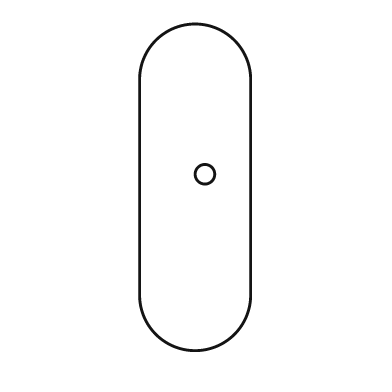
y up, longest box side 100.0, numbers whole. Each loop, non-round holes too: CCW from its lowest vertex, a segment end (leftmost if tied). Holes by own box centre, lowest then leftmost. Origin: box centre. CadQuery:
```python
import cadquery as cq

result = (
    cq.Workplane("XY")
    .moveTo(-17.0, -33.0)
    .threePointArc((0.0, -50.0), (17.0, -33.0))
    .lineTo(17.0, 33.0)
    .threePointArc((0.0, 50.0), (-17.0, 33.0))
    .close()
    .moveTo(3.0, 4.0)
    .circle(3.0)
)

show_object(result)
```